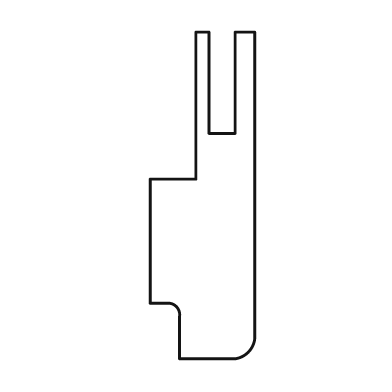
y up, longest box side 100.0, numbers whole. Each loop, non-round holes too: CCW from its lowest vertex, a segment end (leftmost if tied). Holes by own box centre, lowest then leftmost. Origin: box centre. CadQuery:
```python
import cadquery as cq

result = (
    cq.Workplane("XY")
    .moveTo(-7.0, -50.0)
    .lineTo(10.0, -50.0)
    .threePointArc((14.0, -48.0), (16.0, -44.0))
    .lineTo(16.0, 50.0)
    .lineTo(10.0, 50.0)
    .lineTo(10.0, 19.0)
    .lineTo(2.0, 19.0)
    .lineTo(2.0, 50.0)
    .lineTo(-2.0, 50.0)
    .lineTo(-2.0, 5.0)
    .lineTo(-16.0, 5.0)
    .lineTo(-16.0, -33.0)
    .lineTo(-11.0, -33.0)
    .threePointArc((-8.0, -34.0), (-7.0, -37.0))
    .close()
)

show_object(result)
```